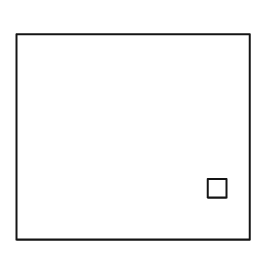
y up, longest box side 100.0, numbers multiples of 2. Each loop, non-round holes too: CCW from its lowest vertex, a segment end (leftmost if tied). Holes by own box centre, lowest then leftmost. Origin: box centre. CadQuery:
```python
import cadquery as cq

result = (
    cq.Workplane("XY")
    .moveTo(-50.0, -44.0)
    .lineTo(50.0, -44.0)
    .lineTo(50.0, 44.0)
    .lineTo(-50.0, 44.0)
    .close()
    .moveTo(32.0, -26.0)
    .lineTo(40.0, -26.0)
    .lineTo(40.0, -18.0)
    .lineTo(32.0, -18.0)
    .close()
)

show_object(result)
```